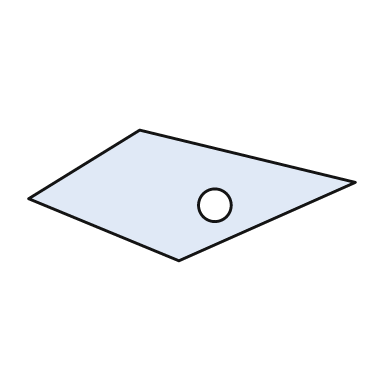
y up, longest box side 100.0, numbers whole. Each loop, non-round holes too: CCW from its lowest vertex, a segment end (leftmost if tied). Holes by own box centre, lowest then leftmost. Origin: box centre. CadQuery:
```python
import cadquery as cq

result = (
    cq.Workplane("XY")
    .moveTo(-4.0, -20.0)
    .lineTo(50.0, 4.0)
    .lineTo(-16.0, 20.0)
    .lineTo(-50.0, -1.0)
    .close()
    .moveTo(7.0, -3.0)
    .circle(5.0)
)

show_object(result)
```